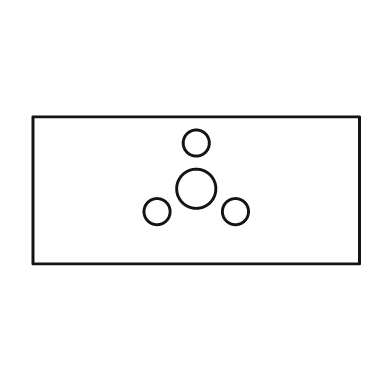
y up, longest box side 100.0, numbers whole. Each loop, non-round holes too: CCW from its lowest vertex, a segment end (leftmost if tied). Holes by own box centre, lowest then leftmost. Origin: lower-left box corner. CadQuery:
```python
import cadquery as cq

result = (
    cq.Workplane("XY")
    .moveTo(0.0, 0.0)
    .lineTo(100.0, 0.0)
    .lineTo(100.0, 45.0)
    .lineTo(0.0, 45.0)
    .close()
    .moveTo(38.0, 16.0)
    .circle(4.0)
    .moveTo(62.0, 16.0)
    .circle(4.0)
    .moveTo(50.0, 23.0)
    .circle(6.0)
    .moveTo(50.0, 37.0)
    .circle(4.0)
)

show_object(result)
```